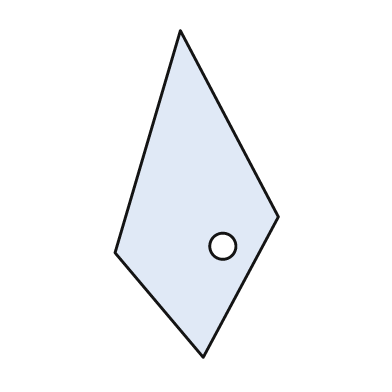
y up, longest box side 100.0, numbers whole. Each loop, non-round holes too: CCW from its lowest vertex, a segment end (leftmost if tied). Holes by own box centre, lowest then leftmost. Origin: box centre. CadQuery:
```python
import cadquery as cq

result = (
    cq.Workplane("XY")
    .moveTo(2.0, -50.0)
    .lineTo(25.0, -7.0)
    .lineTo(-5.0, 50.0)
    .lineTo(-25.0, -18.0)
    .close()
    .moveTo(8.0, -16.0)
    .circle(4.0)
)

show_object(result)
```